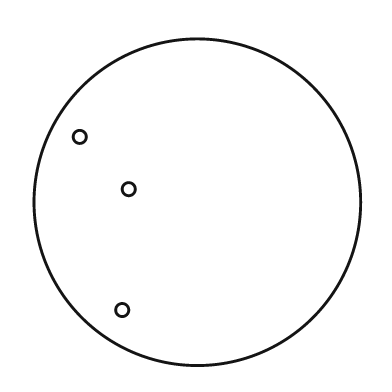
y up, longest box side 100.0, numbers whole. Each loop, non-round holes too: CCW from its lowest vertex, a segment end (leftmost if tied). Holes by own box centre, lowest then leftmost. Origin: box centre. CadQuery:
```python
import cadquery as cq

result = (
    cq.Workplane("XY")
    .moveTo(0.0, 0.0)
    .circle(50.0)
    .moveTo(-23.0, -33.0)
    .circle(2.0)
    .moveTo(-21.0, 4.0)
    .circle(2.0)
    .moveTo(-36.0, 20.0)
    .circle(2.0)
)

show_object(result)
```